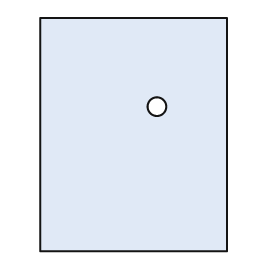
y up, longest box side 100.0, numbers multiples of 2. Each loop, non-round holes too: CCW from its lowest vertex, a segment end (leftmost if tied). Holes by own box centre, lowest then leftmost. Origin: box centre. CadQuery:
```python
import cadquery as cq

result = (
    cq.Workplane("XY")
    .moveTo(-40.0, -50.0)
    .lineTo(40.0, -50.0)
    .lineTo(40.0, 50.0)
    .lineTo(-40.0, 50.0)
    .close()
    .moveTo(10.0, 12.0)
    .circle(4.0)
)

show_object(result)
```